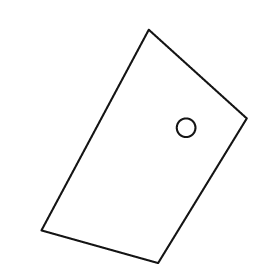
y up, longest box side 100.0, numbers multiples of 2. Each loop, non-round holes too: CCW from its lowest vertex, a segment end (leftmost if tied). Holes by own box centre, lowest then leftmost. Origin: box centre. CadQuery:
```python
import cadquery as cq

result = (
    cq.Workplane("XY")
    .moveTo(6.0, -50.0)
    .lineTo(44.0, 12.0)
    .lineTo(2.0, 50.0)
    .lineTo(-44.0, -36.0)
    .close()
    .moveTo(18.0, 8.0)
    .circle(4.0)
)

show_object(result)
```